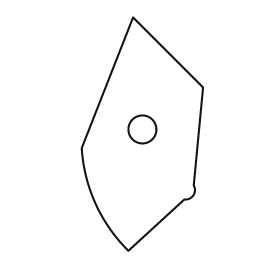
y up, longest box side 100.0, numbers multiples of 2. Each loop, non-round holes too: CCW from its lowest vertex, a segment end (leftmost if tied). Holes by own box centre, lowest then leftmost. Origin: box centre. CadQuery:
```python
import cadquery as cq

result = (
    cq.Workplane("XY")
    .moveTo(-6.0, -50.0)
    .lineTo(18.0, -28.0)
    .threePointArc((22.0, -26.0), (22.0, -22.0))
    .lineTo(26.0, 20.0)
    .lineTo(-4.0, 50.0)
    .lineTo(-26.0, -6.0)
    .threePointArc((-20.0, -30.0), (-6.0, -50.0))
    .close()
    .moveTo(0.0, 2.0)
    .circle(6.0)
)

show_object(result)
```